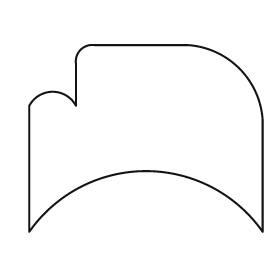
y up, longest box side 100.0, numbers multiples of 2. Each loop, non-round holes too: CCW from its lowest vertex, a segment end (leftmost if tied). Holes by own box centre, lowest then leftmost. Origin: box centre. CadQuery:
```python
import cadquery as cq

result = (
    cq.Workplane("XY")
    .moveTo(-50.0, -40.0)
    .threePointArc((0.0, -14.0), (50.0, -40.0))
    .lineTo(50.0, 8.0)
    .threePointArc((40.0, 30.0), (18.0, 40.0))
    .lineTo(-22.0, 40.0)
    .threePointArc((-28.0, 38.0), (-30.0, 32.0))
    .lineTo(-30.0, 14.0)
    .threePointArc((-40.0, 20.0), (-50.0, 14.0))
    .close()
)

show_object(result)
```